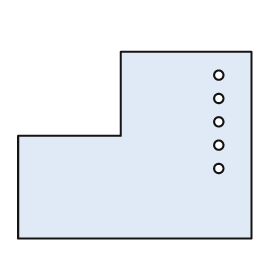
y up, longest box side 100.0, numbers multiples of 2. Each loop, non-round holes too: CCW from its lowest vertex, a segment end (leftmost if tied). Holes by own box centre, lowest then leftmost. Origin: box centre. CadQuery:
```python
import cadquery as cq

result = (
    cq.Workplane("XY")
    .moveTo(-50.0, -40.0)
    .lineTo(50.0, -40.0)
    .lineTo(50.0, 40.0)
    .lineTo(-6.0, 40.0)
    .lineTo(-6.0, 4.0)
    .lineTo(-50.0, 4.0)
    .close()
    .moveTo(36.0, -10.0)
    .circle(2.0)
    .moveTo(36.0, 0.0)
    .circle(2.0)
    .moveTo(36.0, 10.0)
    .circle(2.0)
    .moveTo(36.0, 20.0)
    .circle(2.0)
    .moveTo(36.0, 30.0)
    .circle(2.0)
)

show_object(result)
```